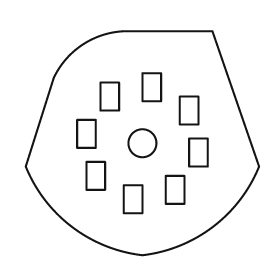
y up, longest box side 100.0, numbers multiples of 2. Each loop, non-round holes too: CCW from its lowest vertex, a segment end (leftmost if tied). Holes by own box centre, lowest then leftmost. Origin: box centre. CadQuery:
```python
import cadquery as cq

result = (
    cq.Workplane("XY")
    .moveTo(0.0, -48.0)
    .threePointArc((30.0, -36.0), (50.0, -10.0))
    .lineTo(30.0, 48.0)
    .lineTo(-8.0, 48.0)
    .threePointArc((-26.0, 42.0), (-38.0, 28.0))
    .lineTo(-50.0, -10.0)
    .threePointArc((-30.0, -36.0), (0.0, -48.0))
    .close()
    .moveTo(-8.0, -30.0)
    .lineTo(0.0, -30.0)
    .lineTo(0.0, -18.0)
    .lineTo(-8.0, -18.0)
    .close()
    .moveTo(10.0, -26.0)
    .lineTo(18.0, -26.0)
    .lineTo(18.0, -14.0)
    .lineTo(10.0, -14.0)
    .close()
    .moveTo(-24.0, -20.0)
    .lineTo(-16.0, -20.0)
    .lineTo(-16.0, -8.0)
    .lineTo(-24.0, -8.0)
    .close()
    .moveTo(20.0, -10.0)
    .lineTo(28.0, -10.0)
    .lineTo(28.0, 2.0)
    .lineTo(20.0, 2.0)
    .close()
    .moveTo(0.0, 0.0)
    .circle(6.0)
    .moveTo(-28.0, -2.0)
    .lineTo(-20.0, -2.0)
    .lineTo(-20.0, 10.0)
    .lineTo(-28.0, 10.0)
    .close()
    .moveTo(16.0, 8.0)
    .lineTo(24.0, 8.0)
    .lineTo(24.0, 20.0)
    .lineTo(16.0, 20.0)
    .close()
    .moveTo(-18.0, 14.0)
    .lineTo(-10.0, 14.0)
    .lineTo(-10.0, 26.0)
    .lineTo(-18.0, 26.0)
    .close()
    .moveTo(0.0, 18.0)
    .lineTo(8.0, 18.0)
    .lineTo(8.0, 30.0)
    .lineTo(0.0, 30.0)
    .close()
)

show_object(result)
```